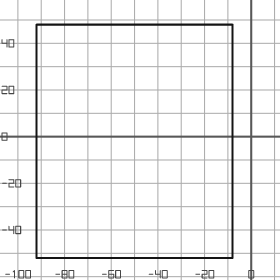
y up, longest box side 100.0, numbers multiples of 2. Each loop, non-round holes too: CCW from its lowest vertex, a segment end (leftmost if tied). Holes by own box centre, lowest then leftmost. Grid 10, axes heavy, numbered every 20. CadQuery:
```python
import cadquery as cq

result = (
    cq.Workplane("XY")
    .moveTo(-92.0, -52.0)
    .lineTo(-8.0, -52.0)
    .lineTo(-8.0, 48.0)
    .lineTo(-92.0, 48.0)
    .close()
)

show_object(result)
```